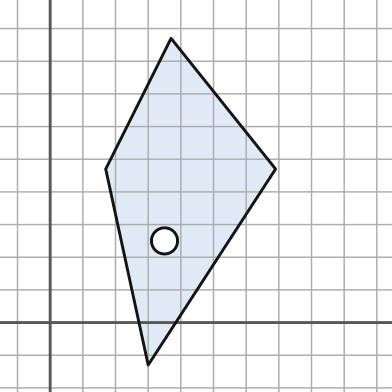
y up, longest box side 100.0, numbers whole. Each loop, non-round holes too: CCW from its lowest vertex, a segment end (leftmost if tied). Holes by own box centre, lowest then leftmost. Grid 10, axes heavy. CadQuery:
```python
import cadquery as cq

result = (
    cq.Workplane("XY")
    .moveTo(30.0, -13.0)
    .lineTo(69.0, 47.0)
    .lineTo(37.0, 87.0)
    .lineTo(17.0, 47.0)
    .close()
    .moveTo(35.0, 25.0)
    .circle(4.0)
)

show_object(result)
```